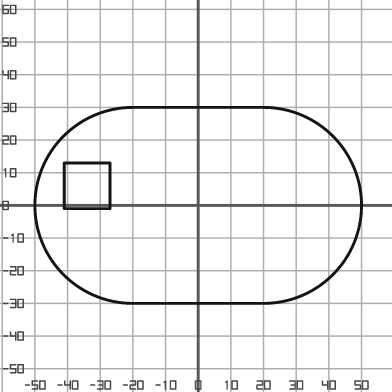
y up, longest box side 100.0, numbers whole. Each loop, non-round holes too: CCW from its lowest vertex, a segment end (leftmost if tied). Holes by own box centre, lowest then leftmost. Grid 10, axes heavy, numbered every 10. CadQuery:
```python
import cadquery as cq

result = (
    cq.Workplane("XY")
    .moveTo(-20.0, -30.0)
    .lineTo(20.0, -30.0)
    .threePointArc((50.0, 0.0), (20.0, 30.0))
    .lineTo(-20.0, 30.0)
    .threePointArc((-50.0, 0.0), (-20.0, -30.0))
    .close()
    .moveTo(-41.0, -1.0)
    .lineTo(-27.0, -1.0)
    .lineTo(-27.0, 13.0)
    .lineTo(-41.0, 13.0)
    .close()
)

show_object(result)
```